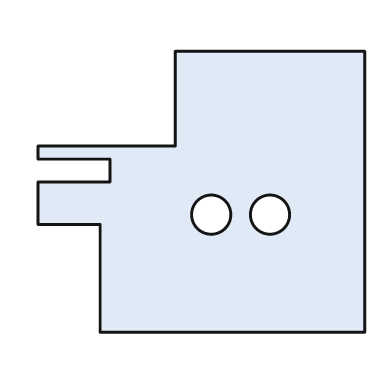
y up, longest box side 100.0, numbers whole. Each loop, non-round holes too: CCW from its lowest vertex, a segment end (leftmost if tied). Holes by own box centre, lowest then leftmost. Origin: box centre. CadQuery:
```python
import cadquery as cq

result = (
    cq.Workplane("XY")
    .moveTo(-31.0, -43.0)
    .lineTo(50.0, -43.0)
    .lineTo(50.0, 43.0)
    .lineTo(-8.0, 43.0)
    .lineTo(-8.0, 14.0)
    .lineTo(-50.0, 14.0)
    .lineTo(-50.0, 10.0)
    .lineTo(-28.0, 10.0)
    .lineTo(-28.0, 3.0)
    .lineTo(-50.0, 3.0)
    .lineTo(-50.0, -10.0)
    .lineTo(-31.0, -10.0)
    .close()
    .moveTo(3.0, -7.0)
    .circle(6.0)
    .moveTo(21.0, -7.0)
    .circle(6.0)
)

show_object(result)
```